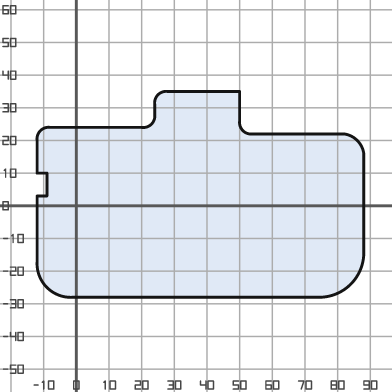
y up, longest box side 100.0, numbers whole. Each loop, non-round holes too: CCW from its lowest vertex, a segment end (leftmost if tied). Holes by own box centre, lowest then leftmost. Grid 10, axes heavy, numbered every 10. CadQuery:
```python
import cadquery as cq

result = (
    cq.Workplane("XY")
    .moveTo(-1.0, -28.0)
    .lineTo(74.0, -28.0)
    .threePointArc((84.0, -24.0), (88.0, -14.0))
    .lineTo(88.0, 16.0)
    .threePointArc((86.0, 20.0), (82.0, 22.0))
    .lineTo(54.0, 22.0)
    .threePointArc((51.0, 23.0), (50.0, 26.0))
    .lineTo(50.0, 35.0)
    .lineTo(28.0, 35.0)
    .threePointArc((25.0, 34.0), (24.0, 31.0))
    .lineTo(24.0, 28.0)
    .threePointArc((23.0, 25.0), (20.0, 24.0))
    .lineTo(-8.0, 24.0)
    .threePointArc((-11.0, 23.0), (-12.0, 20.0))
    .lineTo(-12.0, 10.0)
    .lineTo(-9.0, 10.0)
    .lineTo(-9.0, 3.0)
    .lineTo(-12.0, 3.0)
    .lineTo(-12.0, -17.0)
    .threePointArc((-9.0, -25.0), (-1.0, -28.0))
    .close()
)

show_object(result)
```